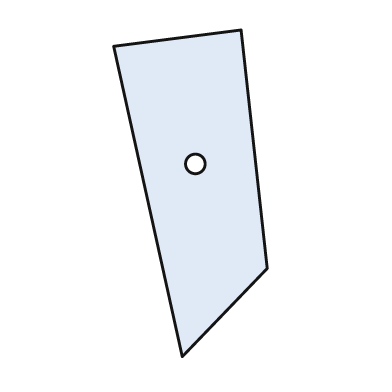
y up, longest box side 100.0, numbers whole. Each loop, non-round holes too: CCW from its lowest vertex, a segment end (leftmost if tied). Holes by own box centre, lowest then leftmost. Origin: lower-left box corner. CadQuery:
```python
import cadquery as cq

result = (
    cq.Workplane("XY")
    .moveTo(21.0, 0.0)
    .lineTo(47.0, 27.0)
    .lineTo(39.0, 100.0)
    .lineTo(0.0, 95.0)
    .close()
    .moveTo(25.0, 59.0)
    .circle(3.0)
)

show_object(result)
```